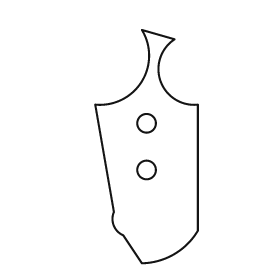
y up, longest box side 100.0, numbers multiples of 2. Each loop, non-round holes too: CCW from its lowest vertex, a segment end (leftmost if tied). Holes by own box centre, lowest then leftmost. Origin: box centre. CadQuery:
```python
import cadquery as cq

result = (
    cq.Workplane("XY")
    .moveTo(-2.0, -50.0)
    .threePointArc((12.0, -46.0), (22.0, -36.0))
    .lineTo(22.0, 18.0)
    .threePointArc((6.0, 28.0), (12.0, 46.0))
    .lineTo(-2.0, 50.0)
    .threePointArc((-2.0, 28.0), (-22.0, 18.0))
    .lineTo(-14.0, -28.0)
    .threePointArc((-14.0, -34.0), (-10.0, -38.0))
    .close()
    .moveTo(0.0, -10.0)
    .circle(4.0)
    .moveTo(0.0, 10.0)
    .circle(4.0)
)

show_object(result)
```